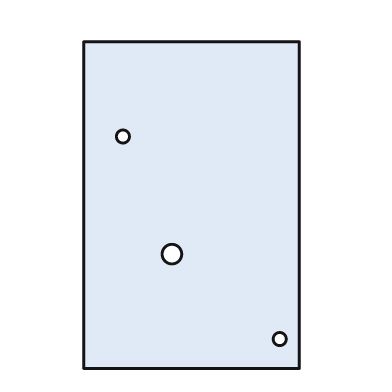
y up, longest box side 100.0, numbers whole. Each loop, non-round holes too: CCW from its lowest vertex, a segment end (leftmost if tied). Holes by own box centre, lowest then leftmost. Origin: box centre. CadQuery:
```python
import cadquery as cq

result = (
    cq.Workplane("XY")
    .moveTo(-33.0, -50.0)
    .lineTo(33.0, -50.0)
    .lineTo(33.0, 50.0)
    .lineTo(-33.0, 50.0)
    .close()
    .moveTo(27.0, -41.0)
    .circle(2.0)
    .moveTo(-6.0, -15.0)
    .circle(3.0)
    .moveTo(-21.0, 21.0)
    .circle(2.0)
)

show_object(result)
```